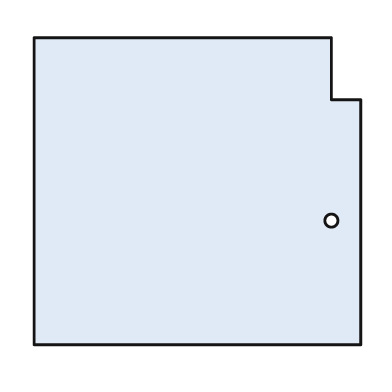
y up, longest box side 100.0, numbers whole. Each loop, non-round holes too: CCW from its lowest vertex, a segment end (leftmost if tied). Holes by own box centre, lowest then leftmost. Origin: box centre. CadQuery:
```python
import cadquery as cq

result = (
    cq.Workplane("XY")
    .moveTo(-50.0, -47.0)
    .lineTo(50.0, -47.0)
    .lineTo(50.0, 28.0)
    .lineTo(41.0, 28.0)
    .lineTo(41.0, 47.0)
    .lineTo(-50.0, 47.0)
    .close()
    .moveTo(41.0, -9.0)
    .circle(2.0)
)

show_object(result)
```